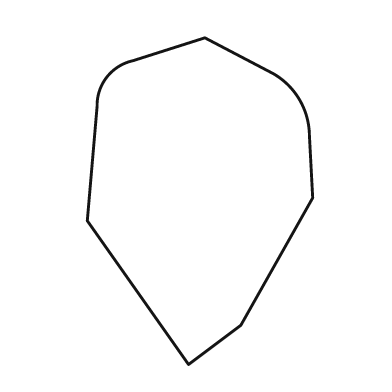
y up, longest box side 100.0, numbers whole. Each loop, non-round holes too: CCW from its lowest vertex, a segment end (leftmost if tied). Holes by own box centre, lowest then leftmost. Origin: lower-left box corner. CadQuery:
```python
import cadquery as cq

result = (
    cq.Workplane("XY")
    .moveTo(31.0, 0.0)
    .lineTo(47.0, 12.0)
    .lineTo(69.0, 51.0)
    .lineTo(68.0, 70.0)
    .threePointArc((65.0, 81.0), (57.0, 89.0))
    .lineTo(36.0, 100.0)
    .lineTo(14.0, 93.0)
    .threePointArc((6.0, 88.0), (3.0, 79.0))
    .lineTo(0.0, 44.0)
    .close()
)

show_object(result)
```